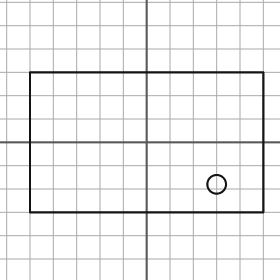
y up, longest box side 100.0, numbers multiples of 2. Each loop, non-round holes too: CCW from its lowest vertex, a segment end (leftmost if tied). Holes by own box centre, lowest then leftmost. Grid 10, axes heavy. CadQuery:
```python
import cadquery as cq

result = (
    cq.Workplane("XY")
    .moveTo(-50.0, -30.0)
    .lineTo(50.0, -30.0)
    .lineTo(50.0, 30.0)
    .lineTo(-50.0, 30.0)
    .close()
    .moveTo(30.0, -18.0)
    .circle(4.0)
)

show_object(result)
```